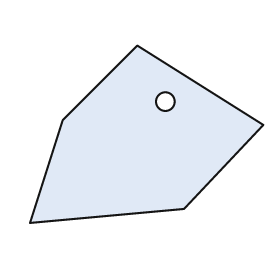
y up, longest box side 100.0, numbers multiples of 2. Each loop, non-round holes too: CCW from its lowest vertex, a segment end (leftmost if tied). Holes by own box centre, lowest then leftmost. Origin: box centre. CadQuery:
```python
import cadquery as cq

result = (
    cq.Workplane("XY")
    .moveTo(-50.0, -38.0)
    .lineTo(16.0, -32.0)
    .lineTo(50.0, 4.0)
    .lineTo(-4.0, 38.0)
    .lineTo(-36.0, 6.0)
    .close()
    .moveTo(8.0, 14.0)
    .circle(4.0)
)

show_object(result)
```